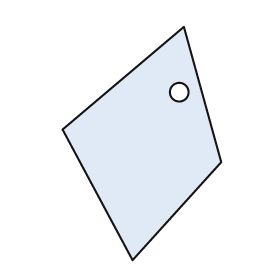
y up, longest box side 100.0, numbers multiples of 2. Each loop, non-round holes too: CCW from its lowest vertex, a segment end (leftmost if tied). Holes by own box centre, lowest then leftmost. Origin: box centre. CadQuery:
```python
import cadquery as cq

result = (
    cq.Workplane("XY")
    .moveTo(-4.0, -50.0)
    .lineTo(34.0, -8.0)
    .lineTo(18.0, 50.0)
    .lineTo(-34.0, 6.0)
    .close()
    .moveTo(16.0, 22.0)
    .circle(4.0)
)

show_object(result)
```